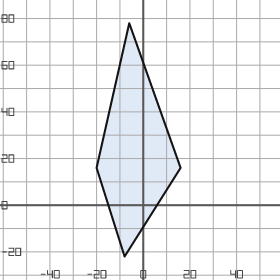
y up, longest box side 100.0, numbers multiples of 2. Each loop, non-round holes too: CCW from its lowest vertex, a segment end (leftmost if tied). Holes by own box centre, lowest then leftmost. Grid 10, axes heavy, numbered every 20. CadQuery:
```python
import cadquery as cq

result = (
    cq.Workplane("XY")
    .moveTo(-8.0, -22.0)
    .lineTo(16.0, 16.0)
    .lineTo(-6.0, 78.0)
    .lineTo(-20.0, 16.0)
    .close()
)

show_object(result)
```